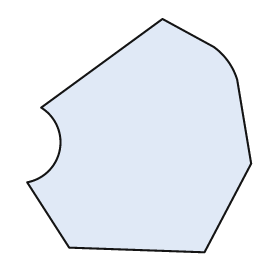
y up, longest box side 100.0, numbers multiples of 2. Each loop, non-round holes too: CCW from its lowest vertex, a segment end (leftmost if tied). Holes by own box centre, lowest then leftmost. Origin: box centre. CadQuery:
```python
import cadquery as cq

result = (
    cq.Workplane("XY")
    .moveTo(28.0, -50.0)
    .lineTo(48.0, -12.0)
    .lineTo(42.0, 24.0)
    .threePointArc((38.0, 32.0), (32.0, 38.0))
    .lineTo(10.0, 50.0)
    .lineTo(-42.0, 12.0)
    .threePointArc((-34.0, -6.0), (-48.0, -20.0))
    .lineTo(-30.0, -48.0)
    .close()
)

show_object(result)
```